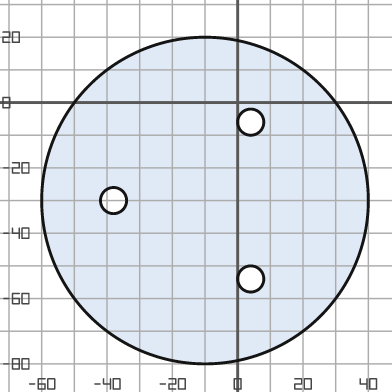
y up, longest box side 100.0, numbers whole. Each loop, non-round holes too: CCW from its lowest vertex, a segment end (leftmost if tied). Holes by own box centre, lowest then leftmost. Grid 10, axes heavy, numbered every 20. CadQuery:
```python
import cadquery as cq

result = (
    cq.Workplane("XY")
    .moveTo(-10.0, -30.0)
    .circle(50.0)
    .moveTo(4.0, -54.0)
    .circle(4.0)
    .moveTo(-38.0, -30.0)
    .circle(4.0)
    .moveTo(4.0, -6.0)
    .circle(4.0)
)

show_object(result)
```